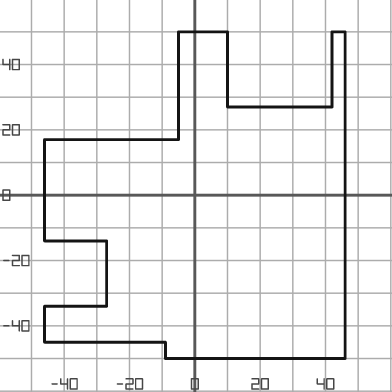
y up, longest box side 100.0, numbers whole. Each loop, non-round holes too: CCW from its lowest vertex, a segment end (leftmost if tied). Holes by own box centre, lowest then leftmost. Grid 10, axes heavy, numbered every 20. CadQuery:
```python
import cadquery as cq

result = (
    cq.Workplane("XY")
    .moveTo(-9.0, -50.0)
    .lineTo(46.0, -50.0)
    .lineTo(46.0, 50.0)
    .lineTo(42.0, 50.0)
    .lineTo(42.0, 27.0)
    .lineTo(10.0, 27.0)
    .lineTo(10.0, 50.0)
    .lineTo(-5.0, 50.0)
    .lineTo(-5.0, 17.0)
    .lineTo(-46.0, 17.0)
    .lineTo(-46.0, -14.0)
    .lineTo(-27.0, -14.0)
    .lineTo(-27.0, -34.0)
    .lineTo(-46.0, -34.0)
    .lineTo(-46.0, -45.0)
    .lineTo(-9.0, -45.0)
    .close()
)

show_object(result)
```